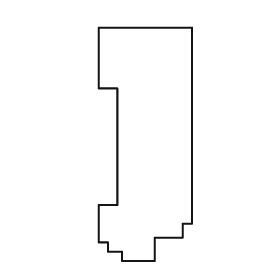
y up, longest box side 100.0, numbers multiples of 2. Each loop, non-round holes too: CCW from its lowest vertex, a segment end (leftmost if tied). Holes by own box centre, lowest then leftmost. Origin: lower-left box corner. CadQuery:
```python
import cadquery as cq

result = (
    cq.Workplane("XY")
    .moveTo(10.0, 0.0)
    .lineTo(24.0, 0.0)
    .lineTo(24.0, 10.0)
    .lineTo(36.0, 10.0)
    .lineTo(36.0, 16.0)
    .lineTo(40.0, 16.0)
    .lineTo(40.0, 100.0)
    .lineTo(0.0, 100.0)
    .lineTo(0.0, 74.0)
    .lineTo(8.0, 74.0)
    .lineTo(8.0, 24.0)
    .lineTo(0.0, 24.0)
    .lineTo(0.0, 8.0)
    .lineTo(4.0, 8.0)
    .lineTo(4.0, 4.0)
    .lineTo(10.0, 4.0)
    .close()
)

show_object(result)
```